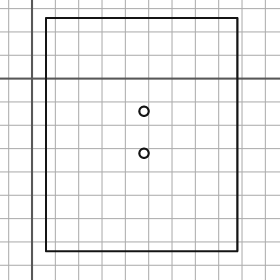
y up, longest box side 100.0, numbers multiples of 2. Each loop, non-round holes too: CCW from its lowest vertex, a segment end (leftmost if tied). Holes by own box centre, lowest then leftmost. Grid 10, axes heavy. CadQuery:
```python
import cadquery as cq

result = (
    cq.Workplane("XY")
    .moveTo(6.0, -74.0)
    .lineTo(88.0, -74.0)
    .lineTo(88.0, 26.0)
    .lineTo(6.0, 26.0)
    .close()
    .moveTo(48.0, -32.0)
    .circle(2.0)
    .moveTo(48.0, -14.0)
    .circle(2.0)
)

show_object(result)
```